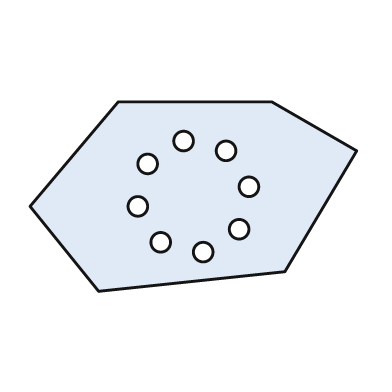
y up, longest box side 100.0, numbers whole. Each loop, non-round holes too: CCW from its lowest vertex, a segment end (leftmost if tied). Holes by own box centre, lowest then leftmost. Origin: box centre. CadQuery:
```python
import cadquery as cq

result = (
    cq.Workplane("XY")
    .moveTo(-29.0, -29.0)
    .lineTo(28.0, -23.0)
    .lineTo(50.0, 14.0)
    .lineTo(24.0, 29.0)
    .lineTo(-23.0, 29.0)
    .lineTo(-50.0, -3.0)
    .close()
    .moveTo(3.0, -17.0)
    .circle(3.0)
    .moveTo(-10.0, -14.0)
    .circle(3.0)
    .moveTo(14.0, -10.0)
    .circle(3.0)
    .moveTo(-17.0, -3.0)
    .circle(3.0)
    .moveTo(17.0, 3.0)
    .circle(3.0)
    .moveTo(-14.0, 10.0)
    .circle(3.0)
    .moveTo(10.0, 14.0)
    .circle(3.0)
    .moveTo(-3.0, 17.0)
    .circle(3.0)
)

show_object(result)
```